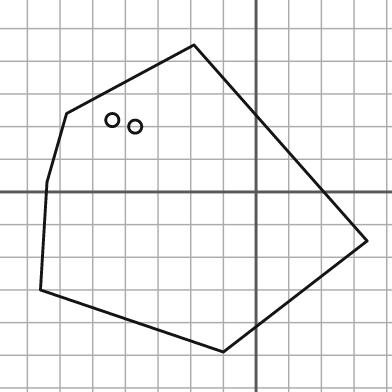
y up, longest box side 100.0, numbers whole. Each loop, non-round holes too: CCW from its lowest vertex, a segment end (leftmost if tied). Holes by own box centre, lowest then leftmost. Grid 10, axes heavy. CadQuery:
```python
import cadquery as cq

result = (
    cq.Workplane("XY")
    .moveTo(-10.0, -49.0)
    .lineTo(34.0, -15.0)
    .lineTo(-19.0, 45.0)
    .lineTo(-58.0, 24.0)
    .lineTo(-64.0, 3.0)
    .lineTo(-66.0, -30.0)
    .close()
    .moveTo(-37.0, 20.0)
    .circle(2.0)
    .moveTo(-44.0, 22.0)
    .circle(2.0)
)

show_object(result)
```